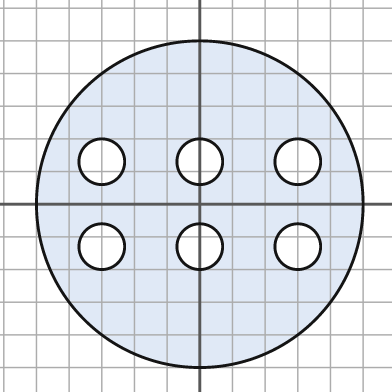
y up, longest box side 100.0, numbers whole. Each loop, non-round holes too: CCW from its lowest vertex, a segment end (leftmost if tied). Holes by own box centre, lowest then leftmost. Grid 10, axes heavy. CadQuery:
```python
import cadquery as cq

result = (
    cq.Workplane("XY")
    .moveTo(0.0, 0.0)
    .circle(50.0)
    .moveTo(-30.0, -13.0)
    .circle(7.0)
    .moveTo(0.0, -13.0)
    .circle(7.0)
    .moveTo(30.0, -13.0)
    .circle(7.0)
    .moveTo(-30.0, 13.0)
    .circle(7.0)
    .moveTo(0.0, 13.0)
    .circle(7.0)
    .moveTo(30.0, 13.0)
    .circle(7.0)
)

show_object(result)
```